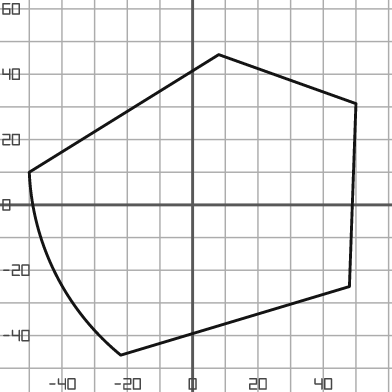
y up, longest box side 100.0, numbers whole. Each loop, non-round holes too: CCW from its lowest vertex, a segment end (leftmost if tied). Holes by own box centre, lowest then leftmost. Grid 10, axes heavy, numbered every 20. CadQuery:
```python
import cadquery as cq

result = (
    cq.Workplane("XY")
    .moveTo(-22.0, -46.0)
    .lineTo(48.0, -25.0)
    .lineTo(50.0, 31.0)
    .lineTo(8.0, 46.0)
    .lineTo(-50.0, 10.0)
    .threePointArc((-42.0, -21.0), (-22.0, -46.0))
    .close()
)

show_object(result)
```